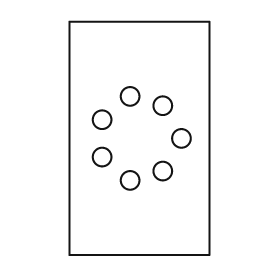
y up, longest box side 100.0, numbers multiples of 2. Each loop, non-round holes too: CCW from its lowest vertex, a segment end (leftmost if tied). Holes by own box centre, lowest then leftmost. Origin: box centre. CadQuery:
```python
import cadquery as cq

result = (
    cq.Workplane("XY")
    .moveTo(-30.0, -50.0)
    .lineTo(30.0, -50.0)
    .lineTo(30.0, 50.0)
    .lineTo(-30.0, 50.0)
    .close()
    .moveTo(-4.0, -18.0)
    .circle(4.0)
    .moveTo(10.0, -14.0)
    .circle(4.0)
    .moveTo(-16.0, -8.0)
    .circle(4.0)
    .moveTo(18.0, 0.0)
    .circle(4.0)
    .moveTo(-16.0, 8.0)
    .circle(4.0)
    .moveTo(10.0, 14.0)
    .circle(4.0)
    .moveTo(-4.0, 18.0)
    .circle(4.0)
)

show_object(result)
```